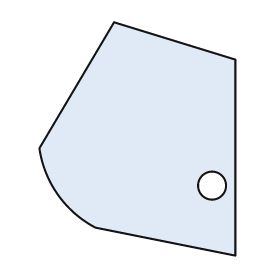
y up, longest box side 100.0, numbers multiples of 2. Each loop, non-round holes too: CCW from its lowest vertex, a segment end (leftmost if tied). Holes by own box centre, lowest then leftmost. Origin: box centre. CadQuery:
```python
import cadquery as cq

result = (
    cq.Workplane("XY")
    .moveTo(42.0, -50.0)
    .lineTo(42.0, 34.0)
    .lineTo(-10.0, 50.0)
    .lineTo(-42.0, -4.0)
    .threePointArc((-34.0, -24.0), (-18.0, -38.0))
    .close()
    .moveTo(32.0, -20.0)
    .circle(6.0)
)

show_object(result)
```